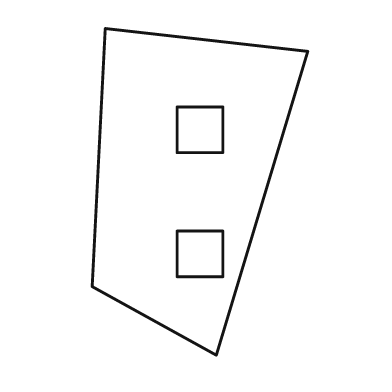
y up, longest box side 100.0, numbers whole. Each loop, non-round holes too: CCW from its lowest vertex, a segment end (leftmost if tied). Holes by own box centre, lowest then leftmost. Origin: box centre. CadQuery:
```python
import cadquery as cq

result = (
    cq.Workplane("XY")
    .moveTo(5.0, -50.0)
    .lineTo(33.0, 43.0)
    .lineTo(-29.0, 50.0)
    .lineTo(-33.0, -29.0)
    .close()
    .moveTo(-7.0, -26.0)
    .lineTo(7.0, -26.0)
    .lineTo(7.0, -12.0)
    .lineTo(-7.0, -12.0)
    .close()
    .moveTo(-7.0, 12.0)
    .lineTo(7.0, 12.0)
    .lineTo(7.0, 26.0)
    .lineTo(-7.0, 26.0)
    .close()
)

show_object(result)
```